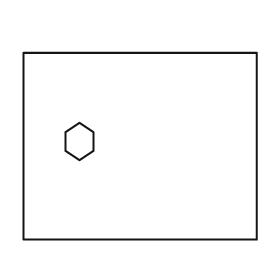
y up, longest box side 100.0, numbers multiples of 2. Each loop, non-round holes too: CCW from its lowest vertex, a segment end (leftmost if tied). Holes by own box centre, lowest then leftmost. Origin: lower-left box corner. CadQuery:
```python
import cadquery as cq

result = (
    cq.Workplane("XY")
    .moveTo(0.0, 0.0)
    .lineTo(100.0, 0.0)
    .lineTo(100.0, 80.0)
    .lineTo(0.0, 80.0)
    .close()
    .moveTo(24.0, 34.0)
    .lineTo(30.0, 38.0)
    .lineTo(30.0, 46.0)
    .lineTo(24.0, 50.0)
    .lineTo(18.0, 46.0)
    .lineTo(18.0, 38.0)
    .close()
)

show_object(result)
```